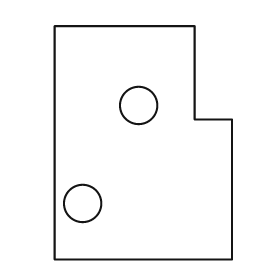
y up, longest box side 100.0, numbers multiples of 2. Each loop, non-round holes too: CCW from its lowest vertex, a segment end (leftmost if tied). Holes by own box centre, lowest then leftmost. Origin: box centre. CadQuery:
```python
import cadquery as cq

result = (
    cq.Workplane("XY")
    .moveTo(-38.0, -50.0)
    .lineTo(38.0, -50.0)
    .lineTo(38.0, 10.0)
    .lineTo(22.0, 10.0)
    .lineTo(22.0, 50.0)
    .lineTo(-38.0, 50.0)
    .close()
    .moveTo(-26.0, -26.0)
    .circle(8.0)
    .moveTo(-2.0, 16.0)
    .circle(8.0)
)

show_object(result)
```